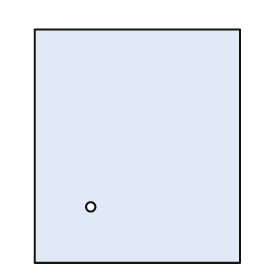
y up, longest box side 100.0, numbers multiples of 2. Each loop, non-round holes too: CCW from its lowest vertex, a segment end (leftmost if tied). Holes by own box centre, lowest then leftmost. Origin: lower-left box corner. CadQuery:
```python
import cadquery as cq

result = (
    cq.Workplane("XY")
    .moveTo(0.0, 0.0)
    .lineTo(88.0, 0.0)
    .lineTo(88.0, 100.0)
    .lineTo(0.0, 100.0)
    .close()
    .moveTo(24.0, 24.0)
    .circle(2.0)
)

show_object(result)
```